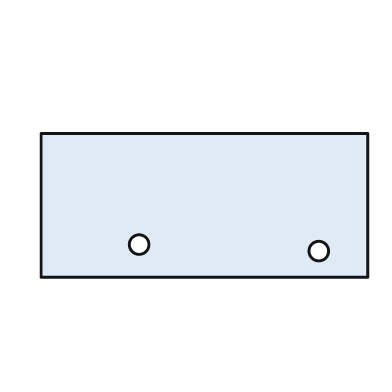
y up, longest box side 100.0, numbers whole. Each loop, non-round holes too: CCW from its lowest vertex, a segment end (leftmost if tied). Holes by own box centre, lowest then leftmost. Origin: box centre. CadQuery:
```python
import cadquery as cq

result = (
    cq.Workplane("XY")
    .moveTo(-50.0, -22.0)
    .lineTo(50.0, -22.0)
    .lineTo(50.0, 22.0)
    .lineTo(-50.0, 22.0)
    .close()
    .moveTo(35.0, -14.0)
    .circle(3.0)
    .moveTo(-20.0, -12.0)
    .circle(3.0)
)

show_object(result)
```